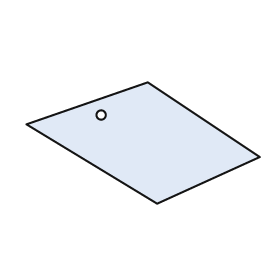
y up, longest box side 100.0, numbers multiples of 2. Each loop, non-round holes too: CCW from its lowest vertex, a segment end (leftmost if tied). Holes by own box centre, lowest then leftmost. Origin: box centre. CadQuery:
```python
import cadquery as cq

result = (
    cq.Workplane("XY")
    .moveTo(6.0, -26.0)
    .lineTo(50.0, -6.0)
    .lineTo(2.0, 26.0)
    .lineTo(-50.0, 8.0)
    .close()
    .moveTo(-18.0, 12.0)
    .circle(2.0)
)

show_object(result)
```